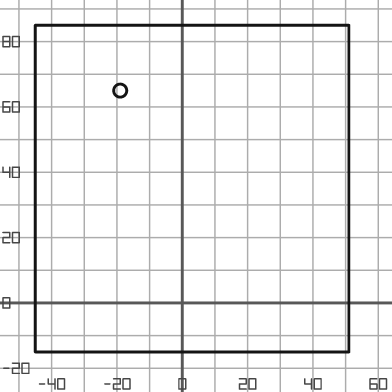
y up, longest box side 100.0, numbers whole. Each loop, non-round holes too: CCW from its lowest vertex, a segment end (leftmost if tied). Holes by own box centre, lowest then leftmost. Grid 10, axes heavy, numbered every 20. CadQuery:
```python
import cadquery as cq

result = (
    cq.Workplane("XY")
    .moveTo(-45.0, -15.0)
    .lineTo(51.0, -15.0)
    .lineTo(51.0, 85.0)
    .lineTo(-45.0, 85.0)
    .close()
    .moveTo(-19.0, 65.0)
    .circle(2.0)
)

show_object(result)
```